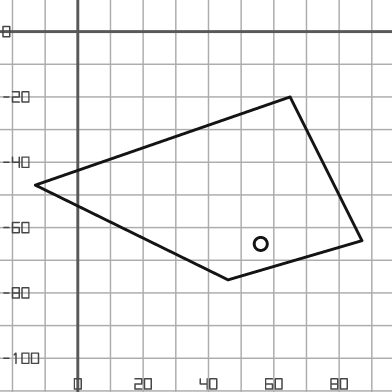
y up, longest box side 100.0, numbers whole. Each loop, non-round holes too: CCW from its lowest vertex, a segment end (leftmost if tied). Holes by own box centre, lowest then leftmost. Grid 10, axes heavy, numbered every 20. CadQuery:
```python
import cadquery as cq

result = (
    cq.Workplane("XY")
    .moveTo(46.0, -76.0)
    .lineTo(87.0, -64.0)
    .lineTo(65.0, -20.0)
    .lineTo(-13.0, -47.0)
    .close()
    .moveTo(56.0, -65.0)
    .circle(2.0)
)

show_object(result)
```